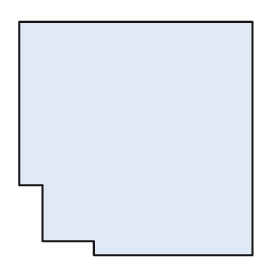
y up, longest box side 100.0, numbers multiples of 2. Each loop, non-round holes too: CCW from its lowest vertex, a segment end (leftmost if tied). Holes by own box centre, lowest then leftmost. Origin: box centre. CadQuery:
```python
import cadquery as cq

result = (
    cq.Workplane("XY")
    .moveTo(-18.0, -50.0)
    .lineTo(50.0, -50.0)
    .lineTo(50.0, 50.0)
    .lineTo(-50.0, 50.0)
    .lineTo(-50.0, -20.0)
    .lineTo(-40.0, -20.0)
    .lineTo(-40.0, -44.0)
    .lineTo(-18.0, -44.0)
    .close()
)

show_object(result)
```